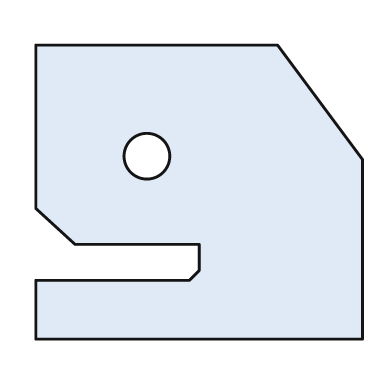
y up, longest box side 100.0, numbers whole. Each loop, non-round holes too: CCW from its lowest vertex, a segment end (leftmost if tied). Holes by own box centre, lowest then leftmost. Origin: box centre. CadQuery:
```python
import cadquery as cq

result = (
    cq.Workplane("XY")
    .moveTo(-50.0, -45.0)
    .lineTo(50.0, -45.0)
    .lineTo(50.0, 10.0)
    .lineTo(24.0, 45.0)
    .lineTo(-50.0, 45.0)
    .lineTo(-50.0, -5.0)
    .lineTo(-38.0, -16.0)
    .lineTo(0.0, -16.0)
    .lineTo(0.0, -24.0)
    .lineTo(-3.0, -27.0)
    .lineTo(-50.0, -27.0)
    .close()
    .moveTo(-16.0, 11.0)
    .circle(7.0)
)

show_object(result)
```